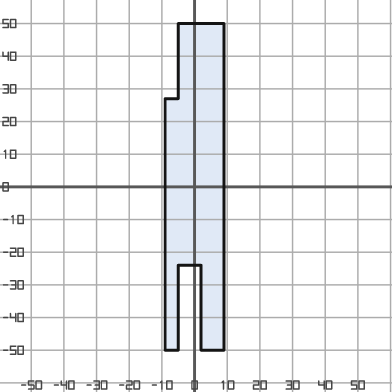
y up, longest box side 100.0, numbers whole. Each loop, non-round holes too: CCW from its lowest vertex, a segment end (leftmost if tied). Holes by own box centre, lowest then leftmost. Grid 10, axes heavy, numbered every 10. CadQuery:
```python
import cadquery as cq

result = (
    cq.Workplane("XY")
    .moveTo(-9.0, -50.0)
    .lineTo(-5.0, -50.0)
    .lineTo(-5.0, -24.0)
    .lineTo(2.0, -24.0)
    .lineTo(2.0, -50.0)
    .lineTo(9.0, -50.0)
    .lineTo(9.0, 50.0)
    .lineTo(-5.0, 50.0)
    .lineTo(-5.0, 27.0)
    .lineTo(-9.0, 27.0)
    .close()
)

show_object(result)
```